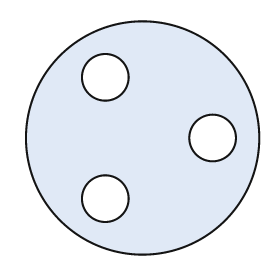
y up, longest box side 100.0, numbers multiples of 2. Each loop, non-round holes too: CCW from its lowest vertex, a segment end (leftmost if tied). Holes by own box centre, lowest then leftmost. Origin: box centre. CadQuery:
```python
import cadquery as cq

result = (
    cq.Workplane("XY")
    .moveTo(0.0, 0.0)
    .circle(50.0)
    .moveTo(-16.0, -26.0)
    .circle(10.0)
    .moveTo(30.0, 0.0)
    .circle(10.0)
    .moveTo(-16.0, 26.0)
    .circle(10.0)
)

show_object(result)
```